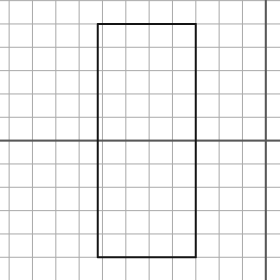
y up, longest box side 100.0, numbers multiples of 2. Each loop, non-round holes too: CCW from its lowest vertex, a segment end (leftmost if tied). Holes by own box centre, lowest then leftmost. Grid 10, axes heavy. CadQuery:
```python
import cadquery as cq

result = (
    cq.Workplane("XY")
    .moveTo(-72.0, -50.0)
    .lineTo(-30.0, -50.0)
    .lineTo(-30.0, 50.0)
    .lineTo(-72.0, 50.0)
    .close()
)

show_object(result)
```